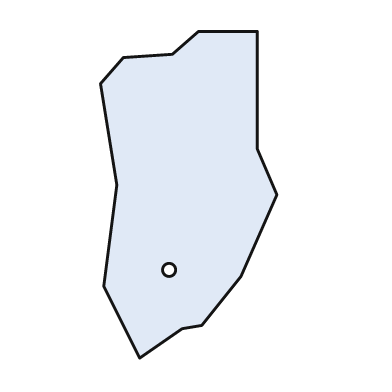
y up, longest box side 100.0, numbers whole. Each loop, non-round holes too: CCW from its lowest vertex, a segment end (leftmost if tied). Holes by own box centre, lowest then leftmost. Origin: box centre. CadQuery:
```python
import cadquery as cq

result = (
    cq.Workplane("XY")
    .moveTo(-15.0, -50.0)
    .lineTo(-2.0, -41.0)
    .lineTo(4.0, -40.0)
    .lineTo(16.0, -25.0)
    .lineTo(27.0, 0.0)
    .lineTo(21.0, 14.0)
    .lineTo(21.0, 50.0)
    .lineTo(3.0, 50.0)
    .lineTo(-5.0, 43.0)
    .lineTo(-20.0, 42.0)
    .lineTo(-27.0, 34.0)
    .lineTo(-22.0, 3.0)
    .lineTo(-26.0, -28.0)
    .close()
    .moveTo(-6.0, -23.0)
    .circle(2.0)
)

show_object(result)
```